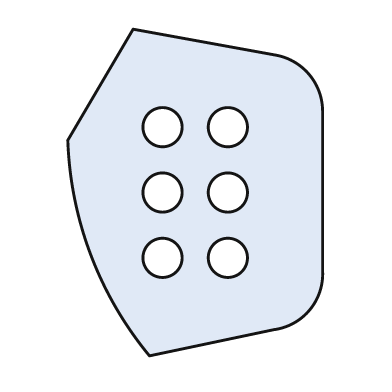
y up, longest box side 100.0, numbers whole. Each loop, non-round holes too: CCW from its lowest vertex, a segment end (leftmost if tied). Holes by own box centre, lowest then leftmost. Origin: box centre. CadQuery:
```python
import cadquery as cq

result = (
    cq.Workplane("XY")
    .moveTo(-14.0, -50.0)
    .lineTo(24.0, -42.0)
    .threePointArc((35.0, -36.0), (39.0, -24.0))
    .lineTo(39.0, 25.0)
    .threePointArc((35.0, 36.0), (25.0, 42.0))
    .lineTo(-19.0, 50.0)
    .lineTo(-39.0, 16.0)
    .threePointArc((-32.0, -19.0), (-14.0, -50.0))
    .close()
    .moveTo(-10.0, -20.0)
    .circle(6.0)
    .moveTo(10.0, -20.0)
    .circle(6.0)
    .moveTo(-10.0, 0.0)
    .circle(6.0)
    .moveTo(10.0, 0.0)
    .circle(6.0)
    .moveTo(-10.0, 20.0)
    .circle(6.0)
    .moveTo(10.0, 20.0)
    .circle(6.0)
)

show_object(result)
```